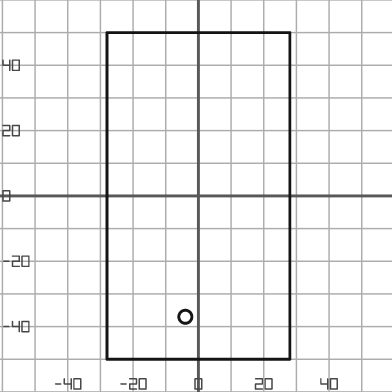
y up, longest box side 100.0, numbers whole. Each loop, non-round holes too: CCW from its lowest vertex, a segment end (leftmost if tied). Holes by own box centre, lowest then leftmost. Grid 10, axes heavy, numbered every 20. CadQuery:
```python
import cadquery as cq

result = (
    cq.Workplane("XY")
    .moveTo(-28.0, -50.0)
    .lineTo(28.0, -50.0)
    .lineTo(28.0, 50.0)
    .lineTo(-28.0, 50.0)
    .close()
    .moveTo(-4.0, -37.0)
    .circle(2.0)
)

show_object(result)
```